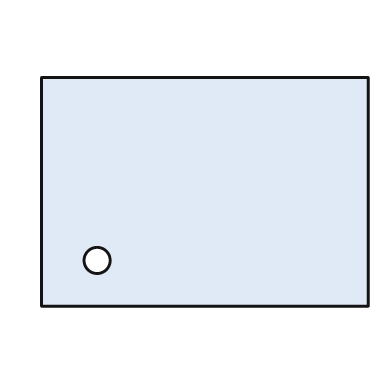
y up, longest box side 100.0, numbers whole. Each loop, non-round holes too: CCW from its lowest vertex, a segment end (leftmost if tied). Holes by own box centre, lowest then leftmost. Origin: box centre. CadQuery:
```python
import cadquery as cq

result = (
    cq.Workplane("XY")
    .moveTo(-50.0, -35.0)
    .lineTo(50.0, -35.0)
    .lineTo(50.0, 35.0)
    .lineTo(-50.0, 35.0)
    .close()
    .moveTo(-33.0, -21.0)
    .circle(4.0)
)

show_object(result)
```